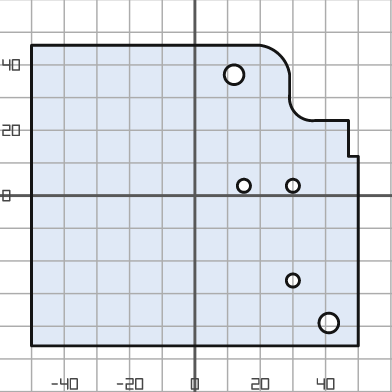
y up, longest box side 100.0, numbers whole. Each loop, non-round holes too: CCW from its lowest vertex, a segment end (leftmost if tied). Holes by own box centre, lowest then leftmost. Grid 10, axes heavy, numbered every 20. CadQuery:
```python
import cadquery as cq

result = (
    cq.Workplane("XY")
    .moveTo(-50.0, -46.0)
    .lineTo(50.0, -46.0)
    .lineTo(50.0, 12.0)
    .lineTo(47.0, 12.0)
    .lineTo(47.0, 23.0)
    .lineTo(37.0, 23.0)
    .threePointArc((31.0, 25.0), (29.0, 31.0))
    .lineTo(29.0, 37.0)
    .threePointArc((26.0, 43.0), (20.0, 46.0))
    .lineTo(-50.0, 46.0)
    .close()
    .moveTo(41.0, -39.0)
    .circle(3.0)
    .moveTo(30.0, -26.0)
    .circle(2.0)
    .moveTo(15.0, 3.0)
    .circle(2.0)
    .moveTo(30.0, 3.0)
    .circle(2.0)
    .moveTo(12.0, 37.0)
    .circle(3.0)
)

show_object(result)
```